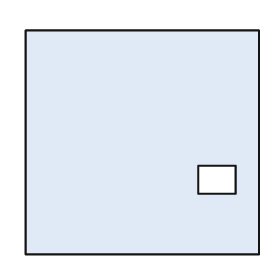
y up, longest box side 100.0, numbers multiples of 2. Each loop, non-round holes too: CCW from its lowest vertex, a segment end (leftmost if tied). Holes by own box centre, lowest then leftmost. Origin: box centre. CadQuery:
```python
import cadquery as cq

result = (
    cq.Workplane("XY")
    .moveTo(-50.0, -48.0)
    .lineTo(50.0, -48.0)
    .lineTo(50.0, 48.0)
    .lineTo(-50.0, 48.0)
    .close()
    .moveTo(24.0, -22.0)
    .lineTo(40.0, -22.0)
    .lineTo(40.0, -10.0)
    .lineTo(24.0, -10.0)
    .close()
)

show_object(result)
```